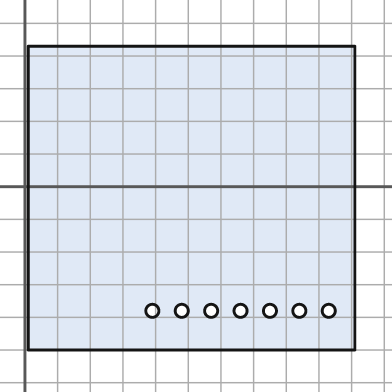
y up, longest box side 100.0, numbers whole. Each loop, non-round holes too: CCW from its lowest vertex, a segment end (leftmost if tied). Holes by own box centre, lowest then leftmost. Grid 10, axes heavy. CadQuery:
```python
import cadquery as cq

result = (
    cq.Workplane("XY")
    .moveTo(1.0, -50.0)
    .lineTo(101.0, -50.0)
    .lineTo(101.0, 43.0)
    .lineTo(1.0, 43.0)
    .close()
    .moveTo(39.0, -38.0)
    .circle(2.0)
    .moveTo(48.0, -38.0)
    .circle(2.0)
    .moveTo(57.0, -38.0)
    .circle(2.0)
    .moveTo(66.0, -38.0)
    .circle(2.0)
    .moveTo(75.0, -38.0)
    .circle(2.0)
    .moveTo(84.0, -38.0)
    .circle(2.0)
    .moveTo(93.0, -38.0)
    .circle(2.0)
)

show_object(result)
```